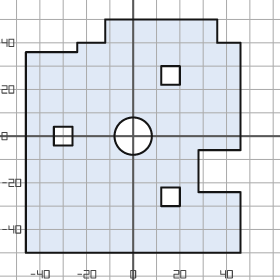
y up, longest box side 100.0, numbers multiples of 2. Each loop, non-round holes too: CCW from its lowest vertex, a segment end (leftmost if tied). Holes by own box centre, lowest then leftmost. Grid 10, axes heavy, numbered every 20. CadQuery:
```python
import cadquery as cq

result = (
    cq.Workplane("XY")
    .moveTo(-46.0, -50.0)
    .lineTo(46.0, -50.0)
    .lineTo(46.0, -24.0)
    .lineTo(28.0, -24.0)
    .lineTo(28.0, -6.0)
    .lineTo(46.0, -6.0)
    .lineTo(46.0, 40.0)
    .lineTo(36.0, 40.0)
    .lineTo(36.0, 50.0)
    .lineTo(-12.0, 50.0)
    .lineTo(-12.0, 40.0)
    .lineTo(-24.0, 40.0)
    .lineTo(-24.0, 36.0)
    .lineTo(-46.0, 36.0)
    .close()
    .moveTo(12.0, -30.0)
    .lineTo(20.0, -30.0)
    .lineTo(20.0, -22.0)
    .lineTo(12.0, -22.0)
    .close()
    .moveTo(-34.0, -4.0)
    .lineTo(-26.0, -4.0)
    .lineTo(-26.0, 4.0)
    .lineTo(-34.0, 4.0)
    .close()
    .moveTo(0.0, 0.0)
    .circle(8.0)
    .moveTo(12.0, 22.0)
    .lineTo(20.0, 22.0)
    .lineTo(20.0, 30.0)
    .lineTo(12.0, 30.0)
    .close()
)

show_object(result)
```